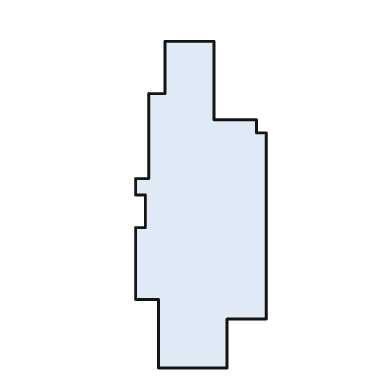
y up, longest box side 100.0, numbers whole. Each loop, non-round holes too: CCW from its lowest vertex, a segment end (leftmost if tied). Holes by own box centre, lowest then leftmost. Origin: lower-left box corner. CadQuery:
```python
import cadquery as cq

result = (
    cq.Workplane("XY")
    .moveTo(7.0, 0.0)
    .lineTo(28.0, 0.0)
    .lineTo(28.0, 15.0)
    .lineTo(40.0, 15.0)
    .lineTo(40.0, 72.0)
    .lineTo(37.0, 72.0)
    .lineTo(37.0, 76.0)
    .lineTo(24.0, 76.0)
    .lineTo(24.0, 100.0)
    .lineTo(9.0, 100.0)
    .lineTo(9.0, 84.0)
    .lineTo(4.0, 84.0)
    .lineTo(4.0, 58.0)
    .lineTo(0.0, 58.0)
    .lineTo(0.0, 53.0)
    .lineTo(3.0, 53.0)
    .lineTo(3.0, 43.0)
    .lineTo(0.0, 43.0)
    .lineTo(0.0, 21.0)
    .lineTo(7.0, 21.0)
    .close()
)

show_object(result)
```